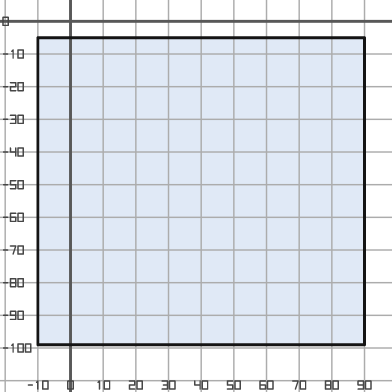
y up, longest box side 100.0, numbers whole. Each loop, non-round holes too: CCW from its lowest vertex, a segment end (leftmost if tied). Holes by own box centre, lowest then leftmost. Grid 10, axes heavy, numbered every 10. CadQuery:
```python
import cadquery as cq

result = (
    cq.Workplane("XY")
    .moveTo(-10.0, -99.0)
    .lineTo(90.0, -99.0)
    .lineTo(90.0, -5.0)
    .lineTo(-10.0, -5.0)
    .close()
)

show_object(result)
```